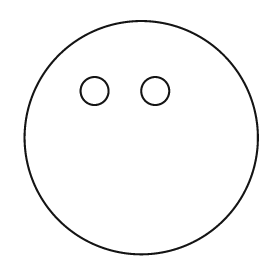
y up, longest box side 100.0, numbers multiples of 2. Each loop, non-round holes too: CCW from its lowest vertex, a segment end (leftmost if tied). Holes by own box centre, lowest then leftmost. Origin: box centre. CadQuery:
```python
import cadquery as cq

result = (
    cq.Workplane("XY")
    .moveTo(0.0, 0.0)
    .circle(50.0)
    .moveTo(-20.0, 20.0)
    .circle(6.0)
    .moveTo(6.0, 20.0)
    .circle(6.0)
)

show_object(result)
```